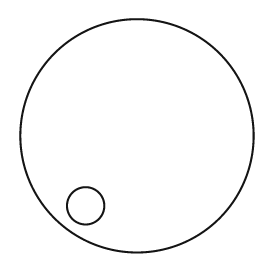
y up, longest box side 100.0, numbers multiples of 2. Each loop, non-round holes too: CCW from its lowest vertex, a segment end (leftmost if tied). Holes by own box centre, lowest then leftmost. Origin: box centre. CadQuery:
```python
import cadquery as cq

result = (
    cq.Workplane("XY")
    .moveTo(0.0, 0.0)
    .circle(50.0)
    .moveTo(-22.0, -30.0)
    .circle(8.0)
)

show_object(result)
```